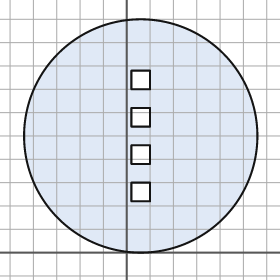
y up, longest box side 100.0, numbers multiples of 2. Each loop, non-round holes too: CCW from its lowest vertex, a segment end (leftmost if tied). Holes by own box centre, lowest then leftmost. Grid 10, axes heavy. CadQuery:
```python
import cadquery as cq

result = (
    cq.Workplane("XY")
    .moveTo(6.0, 50.0)
    .circle(50.0)
    .moveTo(2.0, 22.0)
    .lineTo(10.0, 22.0)
    .lineTo(10.0, 30.0)
    .lineTo(2.0, 30.0)
    .close()
    .moveTo(2.0, 38.0)
    .lineTo(10.0, 38.0)
    .lineTo(10.0, 46.0)
    .lineTo(2.0, 46.0)
    .close()
    .moveTo(2.0, 54.0)
    .lineTo(10.0, 54.0)
    .lineTo(10.0, 62.0)
    .lineTo(2.0, 62.0)
    .close()
    .moveTo(2.0, 70.0)
    .lineTo(10.0, 70.0)
    .lineTo(10.0, 78.0)
    .lineTo(2.0, 78.0)
    .close()
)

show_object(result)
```